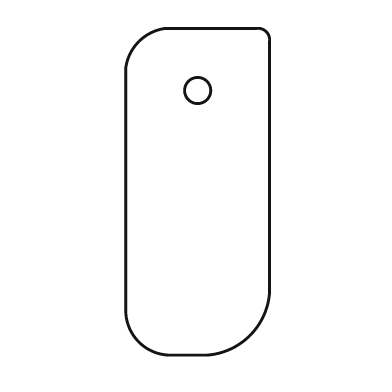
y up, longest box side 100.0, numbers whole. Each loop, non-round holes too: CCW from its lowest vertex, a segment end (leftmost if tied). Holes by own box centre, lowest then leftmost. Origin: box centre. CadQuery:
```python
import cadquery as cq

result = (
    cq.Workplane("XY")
    .moveTo(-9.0, -50.0)
    .lineTo(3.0, -50.0)
    .threePointArc((16.0, -44.0), (22.0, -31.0))
    .lineTo(22.0, 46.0)
    .threePointArc((21.0, 49.0), (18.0, 50.0))
    .lineTo(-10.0, 50.0)
    .threePointArc((-18.0, 46.0), (-22.0, 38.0))
    .lineTo(-22.0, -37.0)
    .threePointArc((-18.0, -46.0), (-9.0, -50.0))
    .close()
    .moveTo(0.0, 31.0)
    .circle(4.0)
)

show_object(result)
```